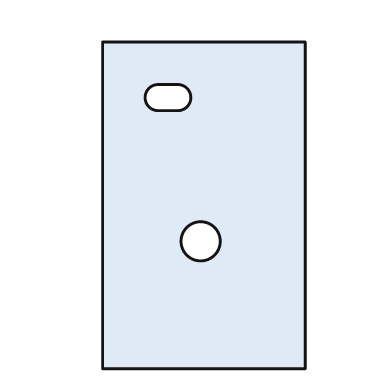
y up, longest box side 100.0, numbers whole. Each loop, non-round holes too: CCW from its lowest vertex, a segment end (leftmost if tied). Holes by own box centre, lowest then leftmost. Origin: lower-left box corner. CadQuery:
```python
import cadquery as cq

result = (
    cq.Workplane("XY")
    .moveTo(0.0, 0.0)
    .lineTo(62.0, 0.0)
    .lineTo(62.0, 100.0)
    .lineTo(0.0, 100.0)
    .close()
    .moveTo(30.0, 39.0)
    .circle(6.0)
    .moveTo(17.0, 79.0)
    .lineTo(23.0, 79.0)
    .threePointArc((27.0, 83.0), (23.0, 87.0))
    .lineTo(17.0, 87.0)
    .threePointArc((13.0, 83.0), (17.0, 79.0))
    .close()
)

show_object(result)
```